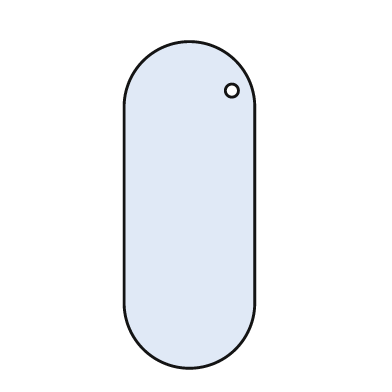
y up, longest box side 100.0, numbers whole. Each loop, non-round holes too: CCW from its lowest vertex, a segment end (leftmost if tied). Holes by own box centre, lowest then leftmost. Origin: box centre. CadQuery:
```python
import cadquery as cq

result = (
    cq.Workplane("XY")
    .moveTo(-20.0, -30.0)
    .threePointArc((0.0, -50.0), (20.0, -30.0))
    .lineTo(20.0, 30.0)
    .threePointArc((0.0, 50.0), (-20.0, 30.0))
    .close()
    .moveTo(13.0, 35.0)
    .circle(2.0)
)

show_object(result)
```